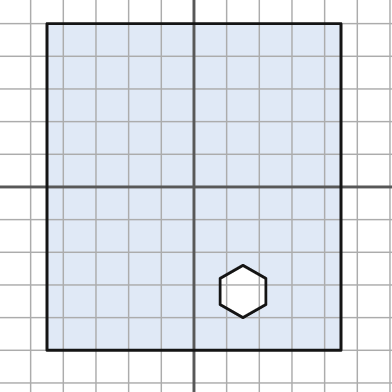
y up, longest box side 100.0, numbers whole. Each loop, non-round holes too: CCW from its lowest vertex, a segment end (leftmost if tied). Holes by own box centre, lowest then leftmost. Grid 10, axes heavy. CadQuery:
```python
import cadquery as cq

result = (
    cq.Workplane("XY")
    .moveTo(-45.0, -50.0)
    .lineTo(45.0, -50.0)
    .lineTo(45.0, 50.0)
    .lineTo(-45.0, 50.0)
    .close()
    .moveTo(15.0, -40.0)
    .lineTo(22.0, -36.0)
    .lineTo(22.0, -28.0)
    .lineTo(15.0, -24.0)
    .lineTo(8.0, -28.0)
    .lineTo(8.0, -36.0)
    .close()
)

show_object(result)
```